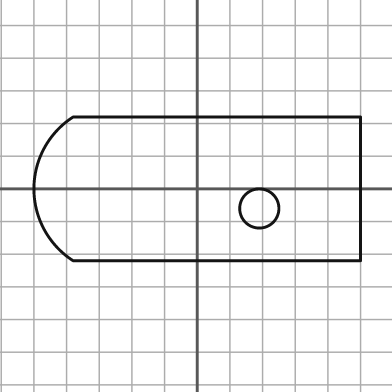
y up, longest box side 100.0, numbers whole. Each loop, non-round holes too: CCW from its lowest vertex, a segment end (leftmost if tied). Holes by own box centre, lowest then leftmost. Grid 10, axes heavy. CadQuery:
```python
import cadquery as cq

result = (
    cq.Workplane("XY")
    .moveTo(-38.0, -22.0)
    .lineTo(50.0, -22.0)
    .lineTo(50.0, 22.0)
    .lineTo(-38.0, 22.0)
    .threePointArc((-50.0, 0.0), (-38.0, -22.0))
    .close()
    .moveTo(19.0, -6.0)
    .circle(6.0)
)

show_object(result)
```